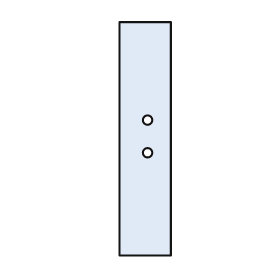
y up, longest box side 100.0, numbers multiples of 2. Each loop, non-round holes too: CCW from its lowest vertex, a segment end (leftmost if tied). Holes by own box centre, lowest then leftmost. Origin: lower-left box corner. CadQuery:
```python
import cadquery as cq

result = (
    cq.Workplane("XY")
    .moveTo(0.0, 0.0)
    .lineTo(22.0, 0.0)
    .lineTo(22.0, 100.0)
    .lineTo(0.0, 100.0)
    .close()
    .moveTo(12.0, 44.0)
    .circle(2.0)
    .moveTo(12.0, 58.0)
    .circle(2.0)
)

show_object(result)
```